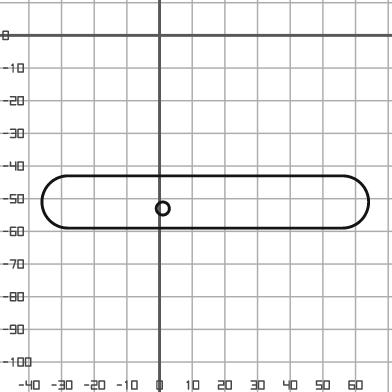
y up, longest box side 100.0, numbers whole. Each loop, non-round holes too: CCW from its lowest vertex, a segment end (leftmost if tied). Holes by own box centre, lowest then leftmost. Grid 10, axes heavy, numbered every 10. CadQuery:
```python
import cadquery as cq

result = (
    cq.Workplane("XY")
    .moveTo(-28.0, -59.0)
    .lineTo(56.0, -59.0)
    .threePointArc((64.0, -51.0), (56.0, -43.0))
    .lineTo(-28.0, -43.0)
    .threePointArc((-36.0, -51.0), (-28.0, -59.0))
    .close()
    .moveTo(1.0, -53.0)
    .circle(2.0)
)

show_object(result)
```